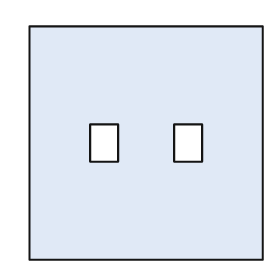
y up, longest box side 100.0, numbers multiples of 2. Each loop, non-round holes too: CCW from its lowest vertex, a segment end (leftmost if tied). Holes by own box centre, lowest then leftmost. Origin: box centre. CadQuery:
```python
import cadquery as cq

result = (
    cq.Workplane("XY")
    .moveTo(-50.0, -50.0)
    .lineTo(50.0, -50.0)
    .lineTo(50.0, 50.0)
    .lineTo(-50.0, 50.0)
    .close()
    .moveTo(-24.0, -8.0)
    .lineTo(-12.0, -8.0)
    .lineTo(-12.0, 8.0)
    .lineTo(-24.0, 8.0)
    .close()
    .moveTo(12.0, -8.0)
    .lineTo(24.0, -8.0)
    .lineTo(24.0, 8.0)
    .lineTo(12.0, 8.0)
    .close()
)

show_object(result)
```